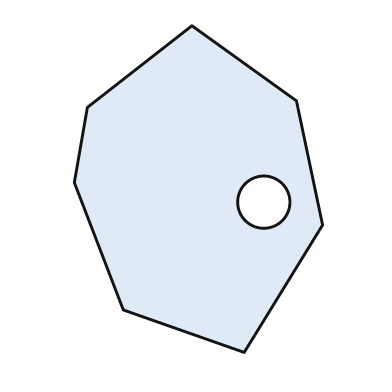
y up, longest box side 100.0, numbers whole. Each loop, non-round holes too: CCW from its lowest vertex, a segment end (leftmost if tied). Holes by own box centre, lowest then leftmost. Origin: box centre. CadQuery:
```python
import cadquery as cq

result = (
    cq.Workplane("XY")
    .moveTo(14.0, -50.0)
    .lineTo(38.0, -11.0)
    .lineTo(30.0, 27.0)
    .lineTo(-2.0, 50.0)
    .lineTo(-34.0, 25.0)
    .lineTo(-38.0, 2.0)
    .lineTo(-23.0, -37.0)
    .close()
    .moveTo(20.0, -4.0)
    .circle(8.0)
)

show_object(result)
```